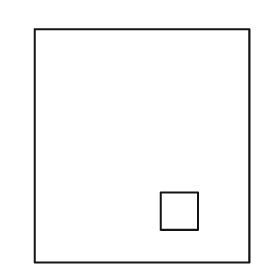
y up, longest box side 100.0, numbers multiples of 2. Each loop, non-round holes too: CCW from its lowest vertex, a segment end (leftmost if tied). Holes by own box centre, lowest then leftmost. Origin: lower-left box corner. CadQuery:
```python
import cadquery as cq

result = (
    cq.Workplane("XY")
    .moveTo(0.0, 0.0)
    .lineTo(92.0, 0.0)
    .lineTo(92.0, 100.0)
    .lineTo(0.0, 100.0)
    .close()
    .moveTo(54.0, 14.0)
    .lineTo(70.0, 14.0)
    .lineTo(70.0, 30.0)
    .lineTo(54.0, 30.0)
    .close()
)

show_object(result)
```